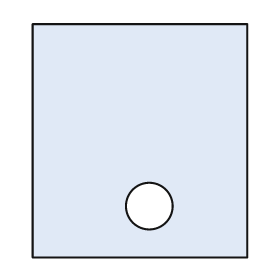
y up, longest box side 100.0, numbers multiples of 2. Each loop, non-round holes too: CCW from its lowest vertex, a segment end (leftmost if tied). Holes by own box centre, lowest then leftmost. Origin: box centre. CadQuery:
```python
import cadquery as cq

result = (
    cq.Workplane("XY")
    .moveTo(-46.0, -50.0)
    .lineTo(46.0, -50.0)
    .lineTo(46.0, 50.0)
    .lineTo(-46.0, 50.0)
    .close()
    .moveTo(4.0, -28.0)
    .circle(10.0)
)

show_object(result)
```